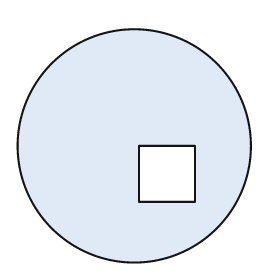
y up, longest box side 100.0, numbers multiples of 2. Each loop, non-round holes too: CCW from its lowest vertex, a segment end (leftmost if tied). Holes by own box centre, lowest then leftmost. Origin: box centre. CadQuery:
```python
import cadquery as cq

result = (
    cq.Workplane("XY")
    .moveTo(0.0, 0.0)
    .circle(50.0)
    .moveTo(2.0, -24.0)
    .lineTo(26.0, -24.0)
    .lineTo(26.0, 0.0)
    .lineTo(2.0, 0.0)
    .close()
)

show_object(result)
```